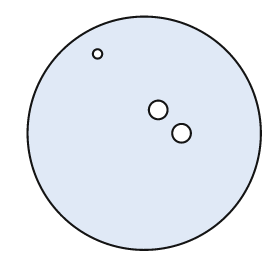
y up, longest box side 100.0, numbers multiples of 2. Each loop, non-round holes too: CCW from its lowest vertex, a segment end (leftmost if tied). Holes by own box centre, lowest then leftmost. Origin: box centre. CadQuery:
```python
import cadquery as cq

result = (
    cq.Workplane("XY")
    .moveTo(0.0, 0.0)
    .circle(50.0)
    .moveTo(16.0, 0.0)
    .circle(4.0)
    .moveTo(6.0, 10.0)
    .circle(4.0)
    .moveTo(-20.0, 34.0)
    .circle(2.0)
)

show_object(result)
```